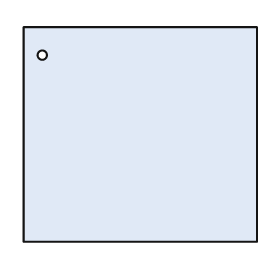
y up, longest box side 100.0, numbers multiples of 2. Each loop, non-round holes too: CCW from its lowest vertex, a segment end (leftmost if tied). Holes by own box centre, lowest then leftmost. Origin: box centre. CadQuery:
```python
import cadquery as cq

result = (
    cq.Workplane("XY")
    .moveTo(-50.0, -46.0)
    .lineTo(50.0, -46.0)
    .lineTo(50.0, 46.0)
    .lineTo(-50.0, 46.0)
    .close()
    .moveTo(-42.0, 34.0)
    .circle(2.0)
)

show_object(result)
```